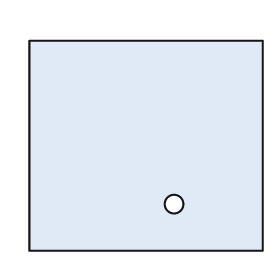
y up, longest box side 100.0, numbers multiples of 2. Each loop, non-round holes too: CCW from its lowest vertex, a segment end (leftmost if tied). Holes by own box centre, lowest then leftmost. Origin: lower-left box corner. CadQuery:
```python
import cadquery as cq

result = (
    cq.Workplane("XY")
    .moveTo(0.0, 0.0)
    .lineTo(100.0, 0.0)
    .lineTo(100.0, 90.0)
    .lineTo(0.0, 90.0)
    .close()
    .moveTo(62.0, 20.0)
    .circle(4.0)
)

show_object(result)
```